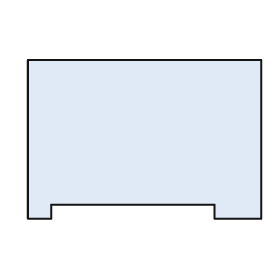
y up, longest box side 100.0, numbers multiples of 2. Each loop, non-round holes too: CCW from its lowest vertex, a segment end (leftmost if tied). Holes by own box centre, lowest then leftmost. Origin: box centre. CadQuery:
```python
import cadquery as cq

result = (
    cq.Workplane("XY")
    .moveTo(-50.0, -34.0)
    .lineTo(-40.0, -34.0)
    .lineTo(-40.0, -28.0)
    .lineTo(30.0, -28.0)
    .lineTo(30.0, -34.0)
    .lineTo(50.0, -34.0)
    .lineTo(50.0, 34.0)
    .lineTo(-50.0, 34.0)
    .close()
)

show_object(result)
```